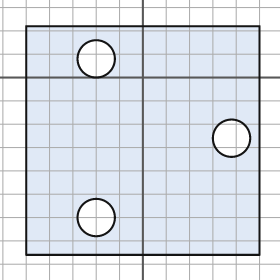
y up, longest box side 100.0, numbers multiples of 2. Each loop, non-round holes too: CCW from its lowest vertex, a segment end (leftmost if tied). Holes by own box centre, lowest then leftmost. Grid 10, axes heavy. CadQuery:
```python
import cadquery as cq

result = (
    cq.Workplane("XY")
    .moveTo(-50.0, -76.0)
    .lineTo(50.0, -76.0)
    .lineTo(50.0, 22.0)
    .lineTo(-50.0, 22.0)
    .close()
    .moveTo(-20.0, -60.0)
    .circle(8.0)
    .moveTo(38.0, -26.0)
    .circle(8.0)
    .moveTo(-20.0, 8.0)
    .circle(8.0)
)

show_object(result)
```